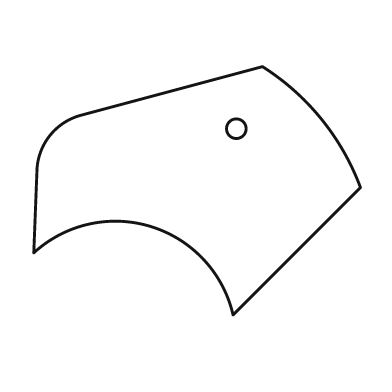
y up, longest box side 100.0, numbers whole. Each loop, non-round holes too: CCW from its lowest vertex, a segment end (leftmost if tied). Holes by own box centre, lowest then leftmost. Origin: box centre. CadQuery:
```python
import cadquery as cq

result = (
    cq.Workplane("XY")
    .moveTo(11.0, -38.0)
    .lineTo(50.0, 1.0)
    .threePointArc((38.0, 22.0), (20.0, 38.0))
    .lineTo(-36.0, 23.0)
    .threePointArc((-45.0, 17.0), (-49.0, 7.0))
    .lineTo(-50.0, -19.0)
    .threePointArc((-14.0, -11.0), (11.0, -38.0))
    .close()
    .moveTo(12.0, 19.0)
    .circle(3.0)
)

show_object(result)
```